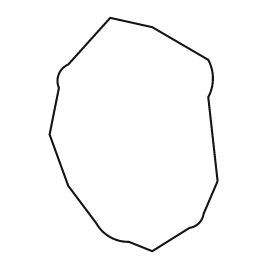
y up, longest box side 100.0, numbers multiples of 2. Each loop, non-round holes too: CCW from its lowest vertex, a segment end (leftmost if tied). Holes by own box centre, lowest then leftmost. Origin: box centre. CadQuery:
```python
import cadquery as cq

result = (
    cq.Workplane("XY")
    .moveTo(8.0, -50.0)
    .lineTo(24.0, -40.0)
    .threePointArc((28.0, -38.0), (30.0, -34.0))
    .lineTo(36.0, -20.0)
    .lineTo(32.0, 16.0)
    .threePointArc((34.0, 24.0), (32.0, 32.0))
    .lineTo(8.0, 46.0)
    .lineTo(-10.0, 50.0)
    .lineTo(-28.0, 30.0)
    .threePointArc((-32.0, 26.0), (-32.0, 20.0))
    .lineTo(-36.0, 0.0)
    .lineTo(-28.0, -22.0)
    .lineTo(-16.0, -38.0)
    .threePointArc((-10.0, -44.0), (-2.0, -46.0))
    .close()
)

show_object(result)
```